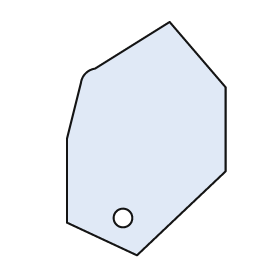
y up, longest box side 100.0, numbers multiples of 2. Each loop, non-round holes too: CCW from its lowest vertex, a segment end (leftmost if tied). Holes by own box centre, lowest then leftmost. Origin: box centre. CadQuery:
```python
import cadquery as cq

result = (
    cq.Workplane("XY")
    .moveTo(-4.0, -50.0)
    .lineTo(34.0, -14.0)
    .lineTo(34.0, 22.0)
    .lineTo(10.0, 50.0)
    .lineTo(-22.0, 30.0)
    .threePointArc((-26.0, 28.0), (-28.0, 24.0))
    .lineTo(-34.0, 0.0)
    .lineTo(-34.0, -36.0)
    .close()
    .moveTo(-10.0, -34.0)
    .circle(4.0)
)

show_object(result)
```